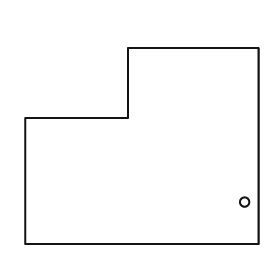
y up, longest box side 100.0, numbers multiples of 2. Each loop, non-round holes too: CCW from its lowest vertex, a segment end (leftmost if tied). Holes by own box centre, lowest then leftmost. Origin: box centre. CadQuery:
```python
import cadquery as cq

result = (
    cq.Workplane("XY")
    .moveTo(-50.0, -42.0)
    .lineTo(50.0, -42.0)
    .lineTo(50.0, 42.0)
    .lineTo(-6.0, 42.0)
    .lineTo(-6.0, 12.0)
    .lineTo(-50.0, 12.0)
    .close()
    .moveTo(44.0, -24.0)
    .circle(2.0)
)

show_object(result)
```